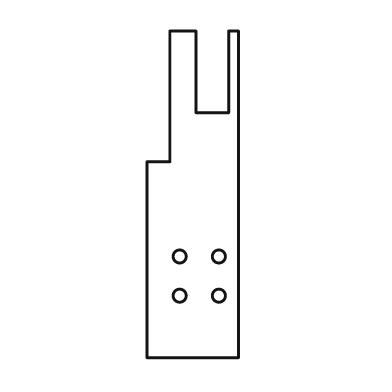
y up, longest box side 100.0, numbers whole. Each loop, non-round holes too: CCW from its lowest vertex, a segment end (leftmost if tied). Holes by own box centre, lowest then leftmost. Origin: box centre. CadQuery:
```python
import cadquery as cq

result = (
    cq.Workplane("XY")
    .moveTo(-14.0, -50.0)
    .lineTo(14.0, -50.0)
    .lineTo(14.0, 50.0)
    .lineTo(11.0, 50.0)
    .lineTo(11.0, 25.0)
    .lineTo(1.0, 25.0)
    .lineTo(1.0, 50.0)
    .lineTo(-7.0, 50.0)
    .lineTo(-7.0, 10.0)
    .lineTo(-14.0, 10.0)
    .close()
    .moveTo(-4.0, -31.0)
    .circle(2.0)
    .moveTo(8.0, -31.0)
    .circle(2.0)
    .moveTo(-4.0, -19.0)
    .circle(2.0)
    .moveTo(8.0, -19.0)
    .circle(2.0)
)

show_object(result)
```